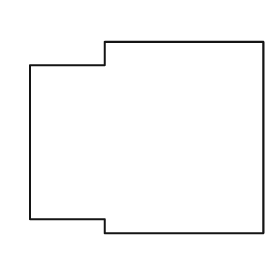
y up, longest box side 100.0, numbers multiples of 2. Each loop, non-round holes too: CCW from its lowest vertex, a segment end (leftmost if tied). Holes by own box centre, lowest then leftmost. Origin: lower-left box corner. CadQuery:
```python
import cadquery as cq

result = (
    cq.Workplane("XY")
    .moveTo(32.0, 0.0)
    .lineTo(100.0, 0.0)
    .lineTo(100.0, 82.0)
    .lineTo(32.0, 82.0)
    .lineTo(32.0, 72.0)
    .lineTo(0.0, 72.0)
    .lineTo(0.0, 6.0)
    .lineTo(32.0, 6.0)
    .close()
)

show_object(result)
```